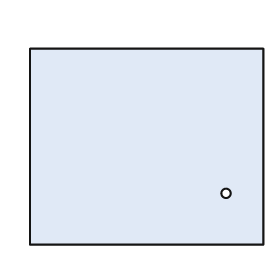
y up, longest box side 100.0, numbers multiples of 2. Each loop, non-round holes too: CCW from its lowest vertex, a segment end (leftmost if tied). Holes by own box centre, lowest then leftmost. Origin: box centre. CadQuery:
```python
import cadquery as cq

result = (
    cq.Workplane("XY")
    .moveTo(-50.0, -42.0)
    .lineTo(50.0, -42.0)
    .lineTo(50.0, 42.0)
    .lineTo(-50.0, 42.0)
    .close()
    .moveTo(34.0, -20.0)
    .circle(2.0)
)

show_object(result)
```